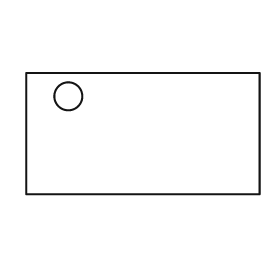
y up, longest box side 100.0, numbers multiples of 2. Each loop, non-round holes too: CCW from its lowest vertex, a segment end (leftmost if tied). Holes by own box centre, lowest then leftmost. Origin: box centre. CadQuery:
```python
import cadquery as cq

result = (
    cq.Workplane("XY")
    .moveTo(-50.0, -26.0)
    .lineTo(50.0, -26.0)
    .lineTo(50.0, 26.0)
    .lineTo(-50.0, 26.0)
    .close()
    .moveTo(-32.0, 16.0)
    .circle(6.0)
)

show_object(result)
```